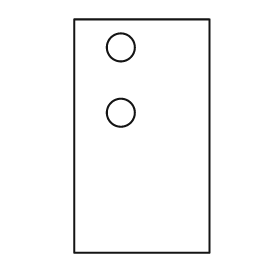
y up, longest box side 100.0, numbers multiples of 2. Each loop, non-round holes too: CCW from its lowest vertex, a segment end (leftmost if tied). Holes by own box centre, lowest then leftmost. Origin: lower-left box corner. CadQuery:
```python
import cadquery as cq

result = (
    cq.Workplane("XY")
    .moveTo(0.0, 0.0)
    .lineTo(58.0, 0.0)
    .lineTo(58.0, 100.0)
    .lineTo(0.0, 100.0)
    .close()
    .moveTo(20.0, 60.0)
    .circle(6.0)
    .moveTo(20.0, 88.0)
    .circle(6.0)
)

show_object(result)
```